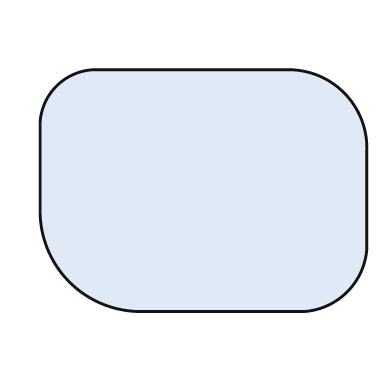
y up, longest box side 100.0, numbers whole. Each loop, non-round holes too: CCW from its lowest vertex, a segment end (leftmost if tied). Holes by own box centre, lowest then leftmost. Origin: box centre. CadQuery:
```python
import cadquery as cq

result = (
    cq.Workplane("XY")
    .moveTo(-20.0, -37.0)
    .lineTo(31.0, -37.0)
    .threePointArc((44.0, -31.0), (50.0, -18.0))
    .lineTo(50.0, 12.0)
    .threePointArc((43.0, 30.0), (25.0, 37.0))
    .lineTo(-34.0, 37.0)
    .threePointArc((-45.0, 32.0), (-50.0, 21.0))
    .lineTo(-50.0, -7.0)
    .threePointArc((-41.0, -28.0), (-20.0, -37.0))
    .close()
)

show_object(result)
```